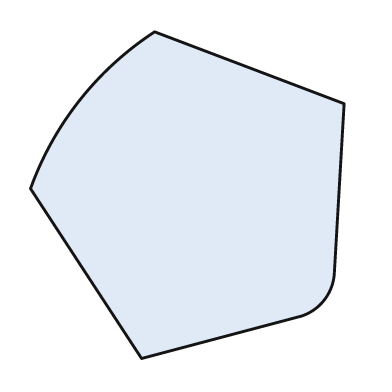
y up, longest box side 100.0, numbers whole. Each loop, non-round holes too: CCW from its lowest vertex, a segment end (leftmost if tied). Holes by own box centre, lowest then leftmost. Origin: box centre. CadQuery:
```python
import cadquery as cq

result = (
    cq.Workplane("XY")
    .moveTo(-14.0, -50.0)
    .lineTo(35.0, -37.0)
    .threePointArc((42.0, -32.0), (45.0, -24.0))
    .lineTo(48.0, 28.0)
    .lineTo(-10.0, 50.0)
    .threePointArc((-33.0, 29.0), (-48.0, 2.0))
    .close()
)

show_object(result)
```